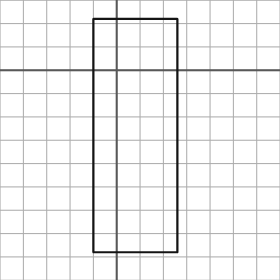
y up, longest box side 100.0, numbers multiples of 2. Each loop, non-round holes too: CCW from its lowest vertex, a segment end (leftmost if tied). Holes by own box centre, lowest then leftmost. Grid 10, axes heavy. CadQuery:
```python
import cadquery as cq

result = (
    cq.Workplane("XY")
    .moveTo(-10.0, -78.0)
    .lineTo(26.0, -78.0)
    .lineTo(26.0, 22.0)
    .lineTo(-10.0, 22.0)
    .close()
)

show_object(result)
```